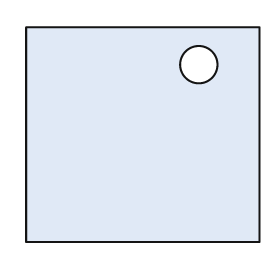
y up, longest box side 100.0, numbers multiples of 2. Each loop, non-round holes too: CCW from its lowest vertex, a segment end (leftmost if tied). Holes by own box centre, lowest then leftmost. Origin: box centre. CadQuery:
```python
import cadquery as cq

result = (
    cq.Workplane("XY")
    .moveTo(-50.0, -46.0)
    .lineTo(50.0, -46.0)
    .lineTo(50.0, 46.0)
    .lineTo(-50.0, 46.0)
    .close()
    .moveTo(24.0, 30.0)
    .circle(8.0)
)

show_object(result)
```